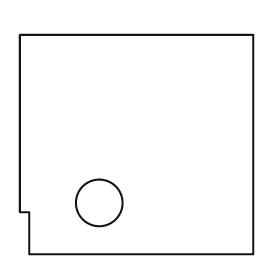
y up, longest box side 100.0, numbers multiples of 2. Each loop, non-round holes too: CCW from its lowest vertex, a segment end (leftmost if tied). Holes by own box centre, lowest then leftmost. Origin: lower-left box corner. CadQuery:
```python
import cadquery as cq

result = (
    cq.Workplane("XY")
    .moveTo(4.0, 0.0)
    .lineTo(100.0, 0.0)
    .lineTo(100.0, 94.0)
    .lineTo(0.0, 94.0)
    .lineTo(0.0, 18.0)
    .lineTo(4.0, 18.0)
    .close()
    .moveTo(34.0, 22.0)
    .circle(10.0)
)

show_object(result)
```